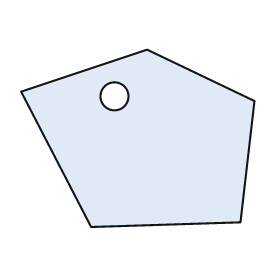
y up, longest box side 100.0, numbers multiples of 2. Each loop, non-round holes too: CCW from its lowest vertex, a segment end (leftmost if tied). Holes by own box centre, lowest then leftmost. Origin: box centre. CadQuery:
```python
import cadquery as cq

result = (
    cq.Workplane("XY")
    .moveTo(-20.0, -38.0)
    .lineTo(44.0, -36.0)
    .lineTo(50.0, 16.0)
    .lineTo(4.0, 38.0)
    .lineTo(-50.0, 20.0)
    .close()
    .moveTo(-10.0, 18.0)
    .circle(6.0)
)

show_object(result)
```